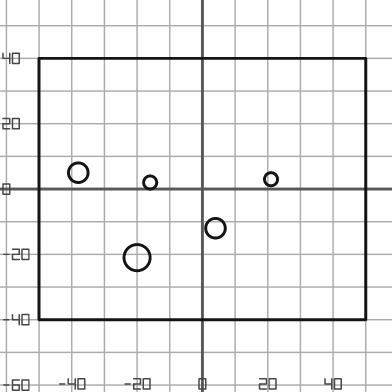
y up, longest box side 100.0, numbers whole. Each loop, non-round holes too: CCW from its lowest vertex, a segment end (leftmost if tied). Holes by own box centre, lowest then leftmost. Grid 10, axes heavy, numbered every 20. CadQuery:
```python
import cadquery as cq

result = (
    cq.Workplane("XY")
    .moveTo(-50.0, -40.0)
    .lineTo(50.0, -40.0)
    .lineTo(50.0, 40.0)
    .lineTo(-50.0, 40.0)
    .close()
    .moveTo(-20.0, -21.0)
    .circle(4.0)
    .moveTo(4.0, -12.0)
    .circle(3.0)
    .moveTo(-16.0, 2.0)
    .circle(2.0)
    .moveTo(21.0, 3.0)
    .circle(2.0)
    .moveTo(-38.0, 5.0)
    .circle(3.0)
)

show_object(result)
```